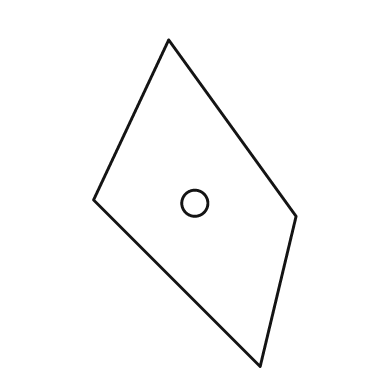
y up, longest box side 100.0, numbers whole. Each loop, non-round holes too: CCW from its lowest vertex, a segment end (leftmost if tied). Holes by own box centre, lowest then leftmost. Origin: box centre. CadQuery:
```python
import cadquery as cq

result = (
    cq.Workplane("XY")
    .moveTo(20.0, -50.0)
    .lineTo(31.0, -4.0)
    .lineTo(-8.0, 50.0)
    .lineTo(-31.0, 1.0)
    .close()
    .moveTo(0.0, 0.0)
    .circle(4.0)
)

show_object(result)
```